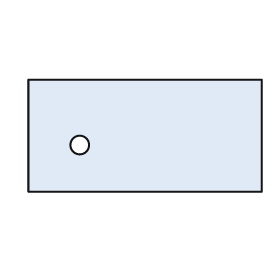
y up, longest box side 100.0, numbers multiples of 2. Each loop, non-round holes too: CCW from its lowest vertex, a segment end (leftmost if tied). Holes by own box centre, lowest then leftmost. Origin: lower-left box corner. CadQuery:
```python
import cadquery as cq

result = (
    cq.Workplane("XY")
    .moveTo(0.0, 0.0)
    .lineTo(100.0, 0.0)
    .lineTo(100.0, 48.0)
    .lineTo(0.0, 48.0)
    .close()
    .moveTo(22.0, 20.0)
    .circle(4.0)
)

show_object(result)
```